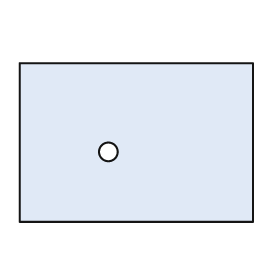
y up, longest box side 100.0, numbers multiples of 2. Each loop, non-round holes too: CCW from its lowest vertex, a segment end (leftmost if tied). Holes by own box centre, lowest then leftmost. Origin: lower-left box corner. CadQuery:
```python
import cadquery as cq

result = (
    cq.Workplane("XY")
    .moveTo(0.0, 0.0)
    .lineTo(100.0, 0.0)
    .lineTo(100.0, 68.0)
    .lineTo(0.0, 68.0)
    .close()
    .moveTo(38.0, 30.0)
    .circle(4.0)
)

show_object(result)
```